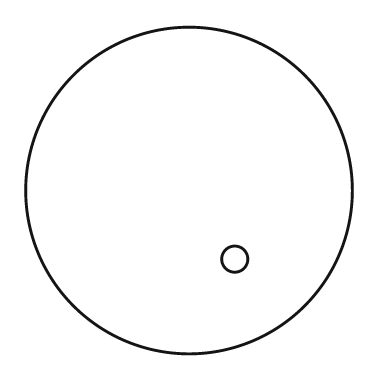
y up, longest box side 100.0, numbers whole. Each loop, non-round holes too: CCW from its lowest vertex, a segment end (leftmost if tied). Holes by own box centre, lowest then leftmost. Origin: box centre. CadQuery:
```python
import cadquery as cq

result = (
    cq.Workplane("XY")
    .moveTo(0.0, 0.0)
    .circle(50.0)
    .moveTo(14.0, -21.0)
    .circle(4.0)
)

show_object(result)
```